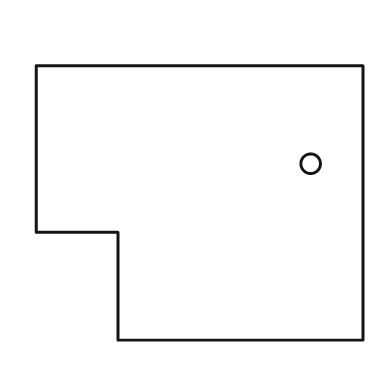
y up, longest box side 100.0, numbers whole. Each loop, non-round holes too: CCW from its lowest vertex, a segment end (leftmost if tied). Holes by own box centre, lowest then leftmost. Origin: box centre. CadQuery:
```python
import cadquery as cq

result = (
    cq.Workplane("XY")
    .moveTo(-25.0, -42.0)
    .lineTo(50.0, -42.0)
    .lineTo(50.0, 42.0)
    .lineTo(-50.0, 42.0)
    .lineTo(-50.0, -9.0)
    .lineTo(-25.0, -9.0)
    .close()
    .moveTo(34.0, 12.0)
    .circle(3.0)
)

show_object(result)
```